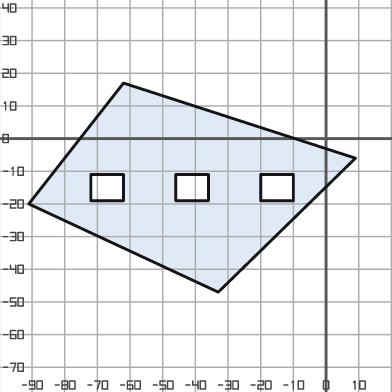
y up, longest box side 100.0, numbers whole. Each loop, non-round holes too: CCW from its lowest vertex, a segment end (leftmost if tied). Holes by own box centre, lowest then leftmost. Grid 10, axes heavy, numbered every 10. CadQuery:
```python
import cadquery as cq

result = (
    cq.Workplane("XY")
    .moveTo(-33.0, -47.0)
    .lineTo(9.0, -6.0)
    .lineTo(-62.0, 17.0)
    .lineTo(-91.0, -20.0)
    .close()
    .moveTo(-72.0, -19.0)
    .lineTo(-62.0, -19.0)
    .lineTo(-62.0, -11.0)
    .lineTo(-72.0, -11.0)
    .close()
    .moveTo(-46.0, -19.0)
    .lineTo(-36.0, -19.0)
    .lineTo(-36.0, -11.0)
    .lineTo(-46.0, -11.0)
    .close()
    .moveTo(-20.0, -19.0)
    .lineTo(-10.0, -19.0)
    .lineTo(-10.0, -11.0)
    .lineTo(-20.0, -11.0)
    .close()
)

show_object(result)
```